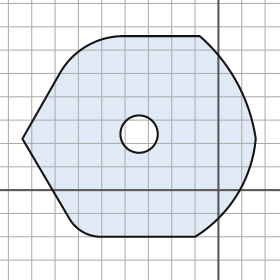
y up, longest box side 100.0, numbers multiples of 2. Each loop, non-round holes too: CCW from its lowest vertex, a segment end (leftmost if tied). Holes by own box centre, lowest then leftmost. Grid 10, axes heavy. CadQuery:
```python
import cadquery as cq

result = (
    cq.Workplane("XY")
    .moveTo(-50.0, -20.0)
    .lineTo(-10.0, -20.0)
    .threePointArc((8.0, -2.0), (16.0, 22.0))
    .threePointArc((8.0, 46.0), (-8.0, 66.0))
    .lineTo(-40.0, 66.0)
    .threePointArc((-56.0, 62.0), (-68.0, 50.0))
    .lineTo(-84.0, 22.0)
    .lineTo(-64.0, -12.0)
    .threePointArc((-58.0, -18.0), (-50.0, -20.0))
    .close()
    .moveTo(-34.0, 24.0)
    .circle(8.0)
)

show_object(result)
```